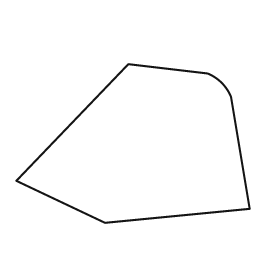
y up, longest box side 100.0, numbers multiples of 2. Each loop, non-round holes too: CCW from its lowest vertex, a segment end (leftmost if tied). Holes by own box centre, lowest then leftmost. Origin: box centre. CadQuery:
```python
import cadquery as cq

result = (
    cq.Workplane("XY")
    .moveTo(-12.0, -34.0)
    .lineTo(50.0, -28.0)
    .lineTo(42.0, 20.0)
    .threePointArc((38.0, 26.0), (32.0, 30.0))
    .lineTo(-2.0, 34.0)
    .lineTo(-50.0, -16.0)
    .close()
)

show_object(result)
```